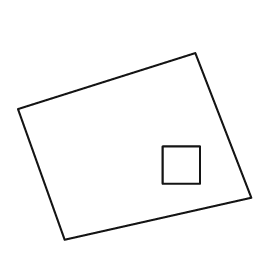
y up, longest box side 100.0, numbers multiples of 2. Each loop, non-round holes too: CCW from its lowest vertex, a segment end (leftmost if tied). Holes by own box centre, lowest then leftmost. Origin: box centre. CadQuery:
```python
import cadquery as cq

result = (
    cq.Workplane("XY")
    .moveTo(-30.0, -40.0)
    .lineTo(50.0, -22.0)
    .lineTo(26.0, 40.0)
    .lineTo(-50.0, 16.0)
    .close()
    .moveTo(12.0, -16.0)
    .lineTo(28.0, -16.0)
    .lineTo(28.0, 0.0)
    .lineTo(12.0, 0.0)
    .close()
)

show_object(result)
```